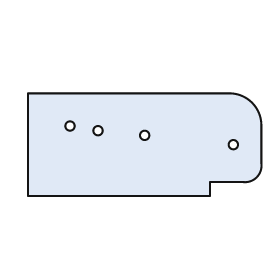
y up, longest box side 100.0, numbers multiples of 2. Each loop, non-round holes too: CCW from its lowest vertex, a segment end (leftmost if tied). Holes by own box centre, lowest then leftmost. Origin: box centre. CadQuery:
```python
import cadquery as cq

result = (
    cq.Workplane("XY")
    .moveTo(-50.0, -22.0)
    .lineTo(28.0, -22.0)
    .lineTo(28.0, -16.0)
    .lineTo(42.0, -16.0)
    .threePointArc((48.0, -14.0), (50.0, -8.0))
    .lineTo(50.0, 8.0)
    .threePointArc((46.0, 18.0), (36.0, 22.0))
    .lineTo(-50.0, 22.0)
    .close()
    .moveTo(38.0, 0.0)
    .circle(2.0)
    .moveTo(0.0, 4.0)
    .circle(2.0)
    .moveTo(-20.0, 6.0)
    .circle(2.0)
    .moveTo(-32.0, 8.0)
    .circle(2.0)
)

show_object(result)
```